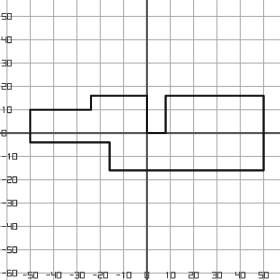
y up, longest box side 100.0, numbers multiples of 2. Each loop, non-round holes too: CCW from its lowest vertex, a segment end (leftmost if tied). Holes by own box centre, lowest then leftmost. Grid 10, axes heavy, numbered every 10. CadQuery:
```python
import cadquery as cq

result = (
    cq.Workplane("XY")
    .moveTo(-16.0, -16.0)
    .lineTo(50.0, -16.0)
    .lineTo(50.0, 16.0)
    .lineTo(8.0, 16.0)
    .lineTo(8.0, 0.0)
    .lineTo(0.0, 0.0)
    .lineTo(0.0, 16.0)
    .lineTo(-24.0, 16.0)
    .lineTo(-24.0, 10.0)
    .lineTo(-50.0, 10.0)
    .lineTo(-50.0, -4.0)
    .lineTo(-16.0, -4.0)
    .close()
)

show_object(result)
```